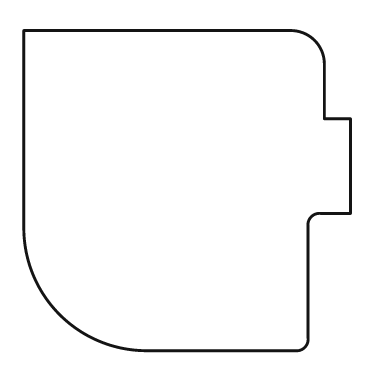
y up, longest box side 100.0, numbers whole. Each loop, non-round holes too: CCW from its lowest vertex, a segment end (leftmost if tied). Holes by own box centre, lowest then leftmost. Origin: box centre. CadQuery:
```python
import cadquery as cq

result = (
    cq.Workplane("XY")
    .moveTo(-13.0, -49.0)
    .lineTo(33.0, -49.0)
    .threePointArc((36.0, -48.0), (37.0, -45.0))
    .lineTo(37.0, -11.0)
    .threePointArc((38.0, -8.0), (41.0, -7.0))
    .lineTo(50.0, -7.0)
    .lineTo(50.0, 22.0)
    .lineTo(42.0, 22.0)
    .lineTo(42.0, 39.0)
    .threePointArc((39.0, 46.0), (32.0, 49.0))
    .lineTo(-50.0, 49.0)
    .lineTo(-50.0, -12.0)
    .threePointArc((-39.0, -38.0), (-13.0, -49.0))
    .close()
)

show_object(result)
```